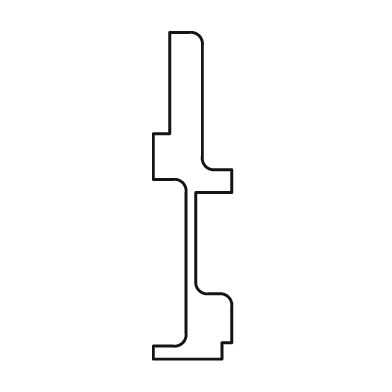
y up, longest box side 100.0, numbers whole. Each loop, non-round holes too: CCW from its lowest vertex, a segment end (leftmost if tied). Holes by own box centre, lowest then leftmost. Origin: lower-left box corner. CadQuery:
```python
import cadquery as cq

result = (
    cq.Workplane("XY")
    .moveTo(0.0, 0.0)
    .lineTo(21.0, 0.0)
    .lineTo(21.0, 5.0)
    .lineTo(24.0, 5.0)
    .lineTo(24.0, 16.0)
    .threePointArc((23.0, 19.0), (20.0, 20.0))
    .lineTo(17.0, 20.0)
    .threePointArc((14.0, 21.0), (13.0, 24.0))
    .lineTo(13.0, 51.0)
    .lineTo(24.0, 51.0)
    .lineTo(24.0, 58.0)
    .lineTo(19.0, 58.0)
    .threePointArc((16.0, 59.0), (15.0, 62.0))
    .lineTo(15.0, 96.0)
    .threePointArc((14.0, 99.0), (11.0, 100.0))
    .lineTo(5.0, 100.0)
    .lineTo(5.0, 69.0)
    .lineTo(0.0, 69.0)
    .lineTo(0.0, 55.0)
    .lineTo(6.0, 55.0)
    .threePointArc((9.0, 54.0), (10.0, 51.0))
    .lineTo(10.0, 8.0)
    .threePointArc((9.0, 5.0), (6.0, 4.0))
    .lineTo(0.0, 4.0)
    .close()
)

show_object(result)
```